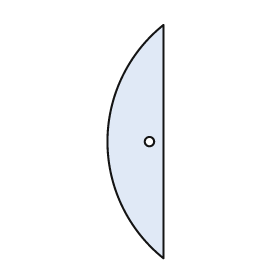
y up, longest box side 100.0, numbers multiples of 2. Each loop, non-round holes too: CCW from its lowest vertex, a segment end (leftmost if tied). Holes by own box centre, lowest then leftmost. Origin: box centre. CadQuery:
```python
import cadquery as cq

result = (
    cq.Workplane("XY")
    .moveTo(12.0, -50.0)
    .lineTo(12.0, 50.0)
    .threePointArc((-12.0, 0.0), (12.0, -50.0))
    .close()
    .moveTo(6.0, 0.0)
    .circle(2.0)
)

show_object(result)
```